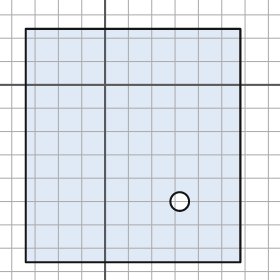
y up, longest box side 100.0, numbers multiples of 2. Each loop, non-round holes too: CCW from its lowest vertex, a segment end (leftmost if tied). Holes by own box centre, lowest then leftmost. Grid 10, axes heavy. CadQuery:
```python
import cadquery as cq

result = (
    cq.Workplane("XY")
    .moveTo(-34.0, -76.0)
    .lineTo(58.0, -76.0)
    .lineTo(58.0, 24.0)
    .lineTo(-34.0, 24.0)
    .close()
    .moveTo(32.0, -50.0)
    .circle(4.0)
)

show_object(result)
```